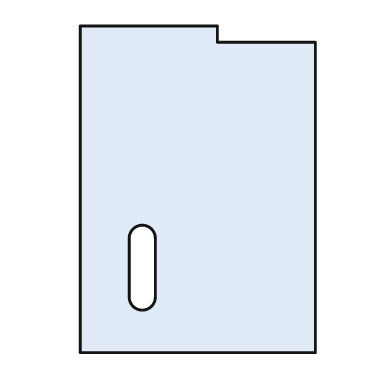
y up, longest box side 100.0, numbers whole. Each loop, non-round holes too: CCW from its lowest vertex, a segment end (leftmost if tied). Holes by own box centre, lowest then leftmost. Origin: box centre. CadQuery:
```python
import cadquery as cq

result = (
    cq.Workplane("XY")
    .moveTo(-36.0, -50.0)
    .lineTo(36.0, -50.0)
    .lineTo(36.0, 45.0)
    .lineTo(6.0, 45.0)
    .lineTo(6.0, 50.0)
    .lineTo(-36.0, 50.0)
    .close()
    .moveTo(-21.0, -33.0)
    .threePointArc((-17.0, -37.0), (-13.0, -33.0))
    .lineTo(-13.0, -15.0)
    .threePointArc((-17.0, -11.0), (-21.0, -15.0))
    .close()
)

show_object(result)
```